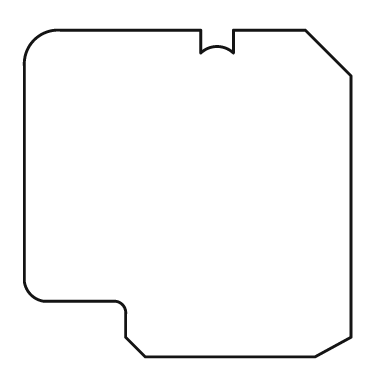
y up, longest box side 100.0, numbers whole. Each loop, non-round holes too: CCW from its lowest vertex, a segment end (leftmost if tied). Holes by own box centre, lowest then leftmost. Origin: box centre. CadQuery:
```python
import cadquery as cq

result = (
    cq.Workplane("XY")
    .moveTo(-13.0, -50.0)
    .lineTo(39.0, -50.0)
    .lineTo(50.0, -44.0)
    .lineTo(50.0, 36.0)
    .lineTo(36.0, 50.0)
    .lineTo(14.0, 50.0)
    .lineTo(14.0, 43.0)
    .threePointArc((9.0, 45.0), (4.0, 43.0))
    .lineTo(4.0, 50.0)
    .lineTo(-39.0, 50.0)
    .threePointArc((-47.0, 47.0), (-50.0, 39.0))
    .lineTo(-50.0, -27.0)
    .threePointArc((-48.0, -31.0), (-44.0, -33.0))
    .lineTo(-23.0, -33.0)
    .threePointArc((-20.0, -34.0), (-19.0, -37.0))
    .lineTo(-19.0, -44.0)
    .close()
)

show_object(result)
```